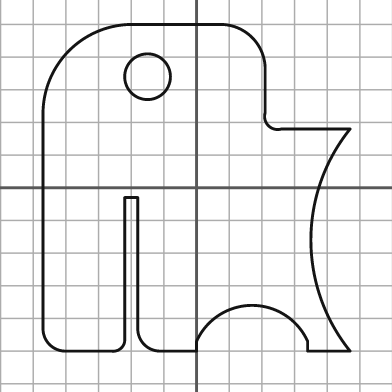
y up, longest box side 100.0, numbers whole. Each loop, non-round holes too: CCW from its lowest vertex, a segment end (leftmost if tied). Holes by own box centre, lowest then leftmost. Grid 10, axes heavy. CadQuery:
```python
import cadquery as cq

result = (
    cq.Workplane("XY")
    .moveTo(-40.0, -50.0)
    .lineTo(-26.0, -50.0)
    .threePointArc((-23.0, -49.0), (-22.0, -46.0))
    .lineTo(-22.0, -3.0)
    .lineTo(-18.0, -3.0)
    .lineTo(-18.0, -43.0)
    .threePointArc((-16.0, -48.0), (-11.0, -50.0))
    .lineTo(0.0, -50.0)
    .lineTo(0.0, -47.0)
    .threePointArc((17.0, -36.0), (34.0, -47.0))
    .lineTo(34.0, -50.0)
    .lineTo(47.0, -50.0)
    .threePointArc((35.0, -16.0), (47.0, 18.0))
    .lineTo(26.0, 18.0)
    .threePointArc((22.0, 19.0), (21.0, 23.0))
    .lineTo(21.0, 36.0)
    .threePointArc((17.0, 46.0), (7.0, 50.0))
    .lineTo(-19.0, 50.0)
    .threePointArc((-39.0, 42.0), (-47.0, 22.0))
    .lineTo(-47.0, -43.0)
    .threePointArc((-45.0, -48.0), (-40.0, -50.0))
    .close()
    .moveTo(-15.0, 34.0)
    .circle(7.0)
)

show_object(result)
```